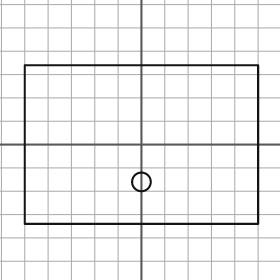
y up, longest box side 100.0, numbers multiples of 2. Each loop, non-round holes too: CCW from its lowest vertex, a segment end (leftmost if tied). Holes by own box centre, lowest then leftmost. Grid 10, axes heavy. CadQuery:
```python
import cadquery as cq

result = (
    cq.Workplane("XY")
    .moveTo(-50.0, -34.0)
    .lineTo(50.0, -34.0)
    .lineTo(50.0, 34.0)
    .lineTo(-50.0, 34.0)
    .close()
    .moveTo(0.0, -16.0)
    .circle(4.0)
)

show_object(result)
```